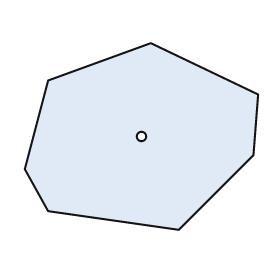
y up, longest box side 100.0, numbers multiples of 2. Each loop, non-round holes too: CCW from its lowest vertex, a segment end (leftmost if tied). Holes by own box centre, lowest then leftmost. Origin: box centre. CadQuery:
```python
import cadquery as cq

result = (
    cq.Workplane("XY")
    .moveTo(16.0, -40.0)
    .lineTo(48.0, -8.0)
    .lineTo(50.0, 18.0)
    .lineTo(4.0, 40.0)
    .lineTo(-40.0, 24.0)
    .lineTo(-50.0, -14.0)
    .lineTo(-40.0, -32.0)
    .close()
    .moveTo(0.0, 0.0)
    .circle(2.0)
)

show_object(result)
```